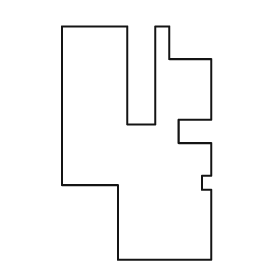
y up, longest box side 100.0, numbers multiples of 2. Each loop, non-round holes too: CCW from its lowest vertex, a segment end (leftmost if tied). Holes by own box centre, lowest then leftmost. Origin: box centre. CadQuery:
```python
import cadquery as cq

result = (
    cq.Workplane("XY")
    .moveTo(-8.0, -50.0)
    .lineTo(32.0, -50.0)
    .lineTo(32.0, -20.0)
    .lineTo(28.0, -20.0)
    .lineTo(28.0, -14.0)
    .lineTo(32.0, -14.0)
    .lineTo(32.0, 0.0)
    .lineTo(18.0, 0.0)
    .lineTo(18.0, 10.0)
    .lineTo(32.0, 10.0)
    .lineTo(32.0, 36.0)
    .lineTo(14.0, 36.0)
    .lineTo(14.0, 50.0)
    .lineTo(8.0, 50.0)
    .lineTo(8.0, 8.0)
    .lineTo(-4.0, 8.0)
    .lineTo(-4.0, 50.0)
    .lineTo(-32.0, 50.0)
    .lineTo(-32.0, -18.0)
    .lineTo(-8.0, -18.0)
    .close()
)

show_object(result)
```